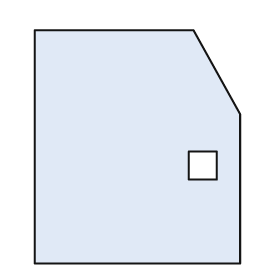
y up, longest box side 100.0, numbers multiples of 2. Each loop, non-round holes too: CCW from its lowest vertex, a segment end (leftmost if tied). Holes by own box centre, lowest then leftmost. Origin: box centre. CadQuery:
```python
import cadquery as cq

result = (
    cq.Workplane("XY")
    .moveTo(-44.0, -50.0)
    .lineTo(44.0, -50.0)
    .lineTo(44.0, 14.0)
    .lineTo(24.0, 50.0)
    .lineTo(-44.0, 50.0)
    .close()
    .moveTo(22.0, -14.0)
    .lineTo(34.0, -14.0)
    .lineTo(34.0, -2.0)
    .lineTo(22.0, -2.0)
    .close()
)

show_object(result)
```